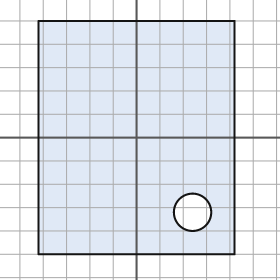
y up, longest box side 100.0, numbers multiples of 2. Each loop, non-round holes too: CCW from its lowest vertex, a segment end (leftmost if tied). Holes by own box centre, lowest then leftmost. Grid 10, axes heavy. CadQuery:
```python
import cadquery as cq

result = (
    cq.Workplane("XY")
    .moveTo(-42.0, -50.0)
    .lineTo(42.0, -50.0)
    .lineTo(42.0, 50.0)
    .lineTo(-42.0, 50.0)
    .close()
    .moveTo(24.0, -32.0)
    .circle(8.0)
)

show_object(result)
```